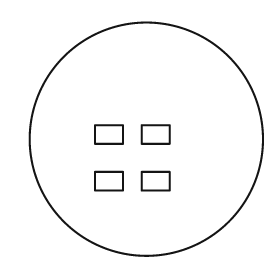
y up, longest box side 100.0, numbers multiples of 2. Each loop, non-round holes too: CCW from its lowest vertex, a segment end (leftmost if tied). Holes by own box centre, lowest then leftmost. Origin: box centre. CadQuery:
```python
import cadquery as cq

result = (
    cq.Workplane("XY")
    .moveTo(0.0, 0.0)
    .circle(50.0)
    .moveTo(-22.0, -22.0)
    .lineTo(-10.0, -22.0)
    .lineTo(-10.0, -14.0)
    .lineTo(-22.0, -14.0)
    .close()
    .moveTo(-2.0, -22.0)
    .lineTo(10.0, -22.0)
    .lineTo(10.0, -14.0)
    .lineTo(-2.0, -14.0)
    .close()
    .moveTo(-22.0, -2.0)
    .lineTo(-10.0, -2.0)
    .lineTo(-10.0, 6.0)
    .lineTo(-22.0, 6.0)
    .close()
    .moveTo(-2.0, -2.0)
    .lineTo(10.0, -2.0)
    .lineTo(10.0, 6.0)
    .lineTo(-2.0, 6.0)
    .close()
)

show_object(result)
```